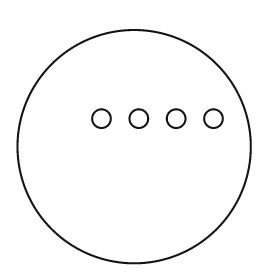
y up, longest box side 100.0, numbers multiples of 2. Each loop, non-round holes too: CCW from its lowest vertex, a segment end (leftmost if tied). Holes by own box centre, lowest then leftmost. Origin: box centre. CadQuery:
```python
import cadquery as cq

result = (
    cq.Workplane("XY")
    .moveTo(0.0, 0.0)
    .circle(50.0)
    .moveTo(-14.0, 12.0)
    .circle(4.0)
    .moveTo(2.0, 12.0)
    .circle(4.0)
    .moveTo(18.0, 12.0)
    .circle(4.0)
    .moveTo(34.0, 12.0)
    .circle(4.0)
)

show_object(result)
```